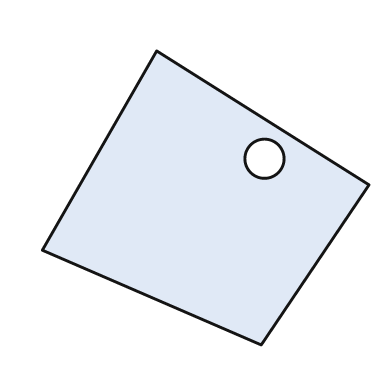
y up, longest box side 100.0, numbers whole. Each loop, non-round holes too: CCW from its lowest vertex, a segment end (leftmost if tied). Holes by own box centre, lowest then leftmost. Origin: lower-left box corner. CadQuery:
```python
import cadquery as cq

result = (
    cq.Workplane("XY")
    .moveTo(67.0, 0.0)
    .lineTo(100.0, 49.0)
    .lineTo(35.0, 90.0)
    .lineTo(0.0, 29.0)
    .close()
    .moveTo(68.0, 57.0)
    .circle(6.0)
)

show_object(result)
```